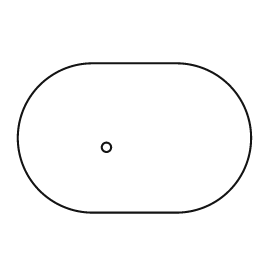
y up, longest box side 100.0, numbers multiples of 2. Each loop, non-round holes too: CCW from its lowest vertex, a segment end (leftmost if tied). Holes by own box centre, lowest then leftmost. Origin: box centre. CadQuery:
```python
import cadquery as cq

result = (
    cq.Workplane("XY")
    .moveTo(-18.0, -32.0)
    .lineTo(18.0, -32.0)
    .threePointArc((50.0, 0.0), (18.0, 32.0))
    .lineTo(-18.0, 32.0)
    .threePointArc((-50.0, 0.0), (-18.0, -32.0))
    .close()
    .moveTo(-12.0, -4.0)
    .circle(2.0)
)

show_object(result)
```